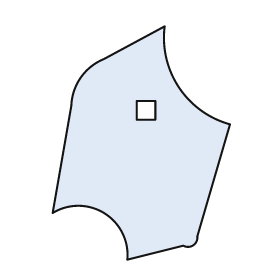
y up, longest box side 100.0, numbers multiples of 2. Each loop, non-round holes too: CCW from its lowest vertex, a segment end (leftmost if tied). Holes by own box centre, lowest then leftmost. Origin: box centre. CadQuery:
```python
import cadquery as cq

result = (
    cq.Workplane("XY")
    .moveTo(-6.0, -50.0)
    .lineTo(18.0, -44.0)
    .threePointArc((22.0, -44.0), (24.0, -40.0))
    .lineTo(38.0, 8.0)
    .threePointArc((16.0, 24.0), (10.0, 50.0))
    .lineTo(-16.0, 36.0)
    .threePointArc((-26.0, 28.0), (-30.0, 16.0))
    .lineTo(-38.0, -30.0)
    .threePointArc((-16.0, -30.0), (-6.0, -50.0))
    .close()
    .moveTo(-2.0, 10.0)
    .lineTo(6.0, 10.0)
    .lineTo(6.0, 18.0)
    .lineTo(-2.0, 18.0)
    .close()
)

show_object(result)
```